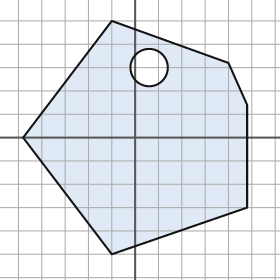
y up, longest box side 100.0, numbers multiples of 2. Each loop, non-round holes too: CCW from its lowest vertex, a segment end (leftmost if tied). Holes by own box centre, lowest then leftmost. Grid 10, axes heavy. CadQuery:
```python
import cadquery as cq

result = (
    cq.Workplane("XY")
    .moveTo(-10.0, -50.0)
    .lineTo(48.0, -30.0)
    .lineTo(48.0, 14.0)
    .lineTo(40.0, 32.0)
    .lineTo(-10.0, 50.0)
    .lineTo(-48.0, 0.0)
    .close()
    .moveTo(6.0, 30.0)
    .circle(8.0)
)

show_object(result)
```